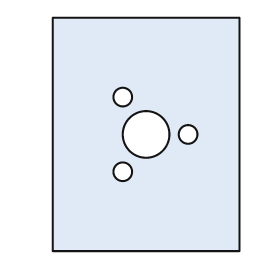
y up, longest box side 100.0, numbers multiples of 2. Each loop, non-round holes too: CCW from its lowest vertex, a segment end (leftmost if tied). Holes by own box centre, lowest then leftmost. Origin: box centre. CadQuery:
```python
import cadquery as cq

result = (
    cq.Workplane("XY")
    .moveTo(-40.0, -50.0)
    .lineTo(40.0, -50.0)
    .lineTo(40.0, 50.0)
    .lineTo(-40.0, 50.0)
    .close()
    .moveTo(-10.0, -16.0)
    .circle(4.0)
    .moveTo(0.0, 0.0)
    .circle(10.0)
    .moveTo(18.0, 0.0)
    .circle(4.0)
    .moveTo(-10.0, 16.0)
    .circle(4.0)
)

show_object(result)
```